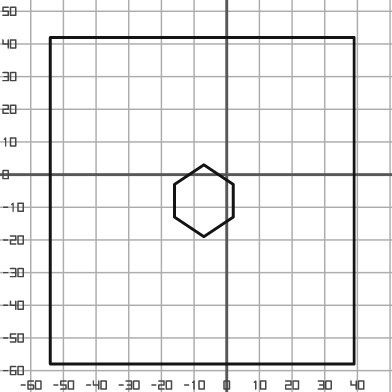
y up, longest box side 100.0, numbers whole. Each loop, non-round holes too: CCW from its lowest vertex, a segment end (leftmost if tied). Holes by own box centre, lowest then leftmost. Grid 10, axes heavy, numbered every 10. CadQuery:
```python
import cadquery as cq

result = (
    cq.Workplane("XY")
    .moveTo(-54.0, -58.0)
    .lineTo(39.0, -58.0)
    .lineTo(39.0, 42.0)
    .lineTo(-54.0, 42.0)
    .close()
    .moveTo(-7.0, -19.0)
    .lineTo(2.0, -13.0)
    .lineTo(2.0, -3.0)
    .lineTo(-7.0, 3.0)
    .lineTo(-16.0, -3.0)
    .lineTo(-16.0, -13.0)
    .close()
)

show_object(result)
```